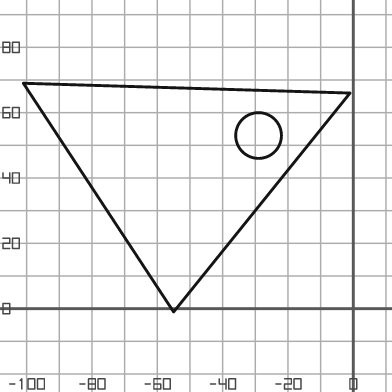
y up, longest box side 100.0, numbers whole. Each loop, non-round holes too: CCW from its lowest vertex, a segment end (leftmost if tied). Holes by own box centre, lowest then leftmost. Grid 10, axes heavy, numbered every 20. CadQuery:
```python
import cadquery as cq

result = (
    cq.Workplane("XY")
    .moveTo(-55.0, -1.0)
    .lineTo(-1.0, 66.0)
    .lineTo(-101.0, 69.0)
    .close()
    .moveTo(-29.0, 53.0)
    .circle(7.0)
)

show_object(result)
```